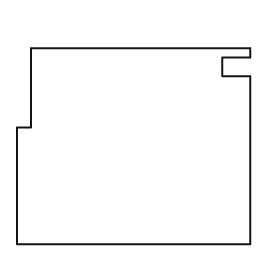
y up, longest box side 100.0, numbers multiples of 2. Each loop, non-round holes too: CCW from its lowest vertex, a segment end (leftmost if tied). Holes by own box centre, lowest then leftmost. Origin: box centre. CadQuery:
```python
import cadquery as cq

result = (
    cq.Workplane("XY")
    .moveTo(-50.0, -42.0)
    .lineTo(50.0, -42.0)
    .lineTo(50.0, 30.0)
    .lineTo(38.0, 30.0)
    .lineTo(38.0, 38.0)
    .lineTo(50.0, 38.0)
    .lineTo(50.0, 42.0)
    .lineTo(-44.0, 42.0)
    .lineTo(-44.0, 8.0)
    .lineTo(-50.0, 8.0)
    .close()
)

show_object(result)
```